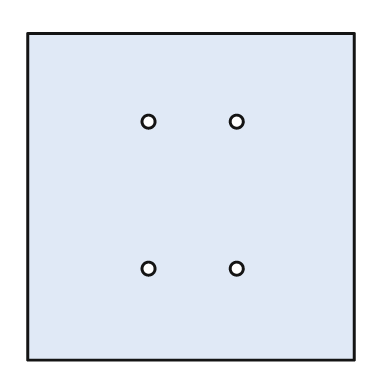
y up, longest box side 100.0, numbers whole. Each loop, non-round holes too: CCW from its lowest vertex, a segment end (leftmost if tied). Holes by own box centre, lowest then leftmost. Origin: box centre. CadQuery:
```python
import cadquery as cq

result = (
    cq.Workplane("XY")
    .moveTo(-50.0, -50.0)
    .lineTo(50.0, -50.0)
    .lineTo(50.0, 50.0)
    .lineTo(-50.0, 50.0)
    .close()
    .moveTo(-13.0, -22.0)
    .circle(2.0)
    .moveTo(14.0, -22.0)
    .circle(2.0)
    .moveTo(-13.0, 23.0)
    .circle(2.0)
    .moveTo(14.0, 23.0)
    .circle(2.0)
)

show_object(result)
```